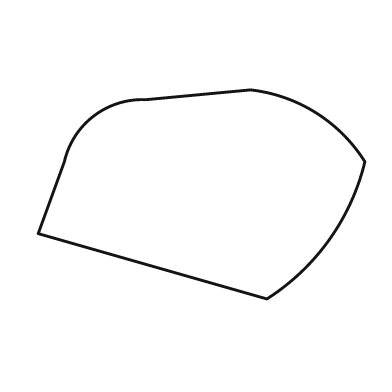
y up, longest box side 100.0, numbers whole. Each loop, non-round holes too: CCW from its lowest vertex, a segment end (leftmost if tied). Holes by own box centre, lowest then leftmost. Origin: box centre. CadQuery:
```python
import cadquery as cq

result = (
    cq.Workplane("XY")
    .moveTo(20.0, -32.0)
    .threePointArc((39.0, -14.0), (50.0, 10.0))
    .threePointArc((35.0, 25.0), (15.0, 32.0))
    .lineTo(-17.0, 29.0)
    .threePointArc((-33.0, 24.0), (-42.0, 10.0))
    .lineTo(-50.0, -12.0)
    .close()
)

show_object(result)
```